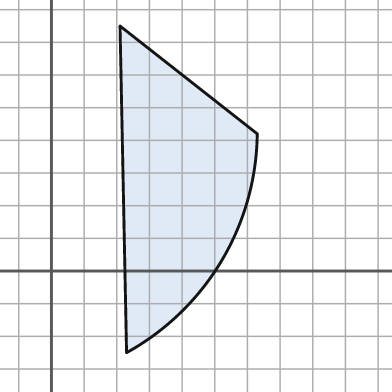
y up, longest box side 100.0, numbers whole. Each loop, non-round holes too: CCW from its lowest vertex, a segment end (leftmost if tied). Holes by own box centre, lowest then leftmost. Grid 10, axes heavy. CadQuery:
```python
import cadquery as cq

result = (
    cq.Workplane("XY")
    .moveTo(23.0, -25.0)
    .threePointArc((52.0, 3.0), (63.0, 42.0))
    .lineTo(21.0, 75.0)
    .close()
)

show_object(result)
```